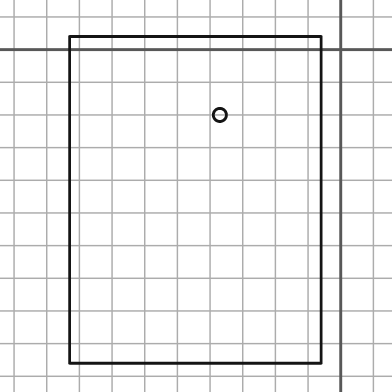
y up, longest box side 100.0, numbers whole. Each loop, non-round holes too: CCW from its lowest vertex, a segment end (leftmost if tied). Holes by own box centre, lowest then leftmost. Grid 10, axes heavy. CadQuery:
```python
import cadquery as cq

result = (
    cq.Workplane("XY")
    .moveTo(-83.0, -96.0)
    .lineTo(-6.0, -96.0)
    .lineTo(-6.0, 4.0)
    .lineTo(-83.0, 4.0)
    .close()
    .moveTo(-37.0, -20.0)
    .circle(2.0)
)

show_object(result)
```